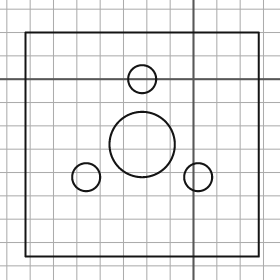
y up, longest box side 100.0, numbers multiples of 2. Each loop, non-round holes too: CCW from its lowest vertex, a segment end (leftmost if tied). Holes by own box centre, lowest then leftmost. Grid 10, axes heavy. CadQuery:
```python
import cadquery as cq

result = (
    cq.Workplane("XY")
    .moveTo(-72.0, -76.0)
    .lineTo(28.0, -76.0)
    .lineTo(28.0, 20.0)
    .lineTo(-72.0, 20.0)
    .close()
    .moveTo(-46.0, -42.0)
    .circle(6.0)
    .moveTo(2.0, -42.0)
    .circle(6.0)
    .moveTo(-22.0, -28.0)
    .circle(14.0)
    .moveTo(-22.0, 0.0)
    .circle(6.0)
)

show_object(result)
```